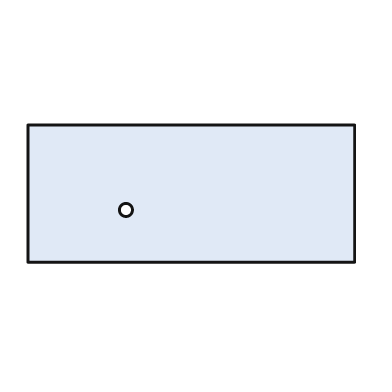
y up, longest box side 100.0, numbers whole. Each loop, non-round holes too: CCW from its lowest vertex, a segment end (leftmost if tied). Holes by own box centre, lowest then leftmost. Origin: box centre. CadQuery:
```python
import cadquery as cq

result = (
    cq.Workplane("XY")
    .moveTo(-50.0, -21.0)
    .lineTo(50.0, -21.0)
    .lineTo(50.0, 21.0)
    .lineTo(-50.0, 21.0)
    .close()
    .moveTo(-20.0, -5.0)
    .circle(2.0)
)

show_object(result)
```